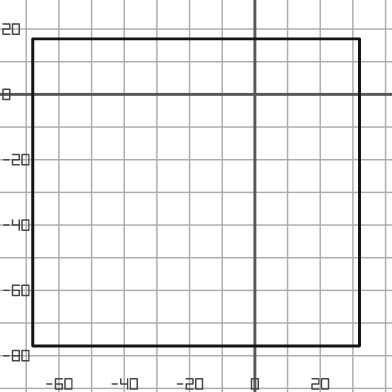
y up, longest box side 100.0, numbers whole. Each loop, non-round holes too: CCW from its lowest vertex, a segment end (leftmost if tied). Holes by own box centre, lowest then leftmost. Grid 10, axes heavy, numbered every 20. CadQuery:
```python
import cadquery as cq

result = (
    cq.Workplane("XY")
    .moveTo(-68.0, -77.0)
    .lineTo(32.0, -77.0)
    .lineTo(32.0, 17.0)
    .lineTo(-68.0, 17.0)
    .close()
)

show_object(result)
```